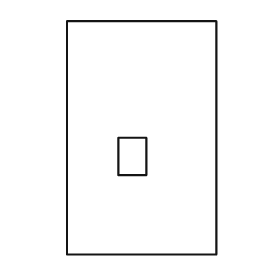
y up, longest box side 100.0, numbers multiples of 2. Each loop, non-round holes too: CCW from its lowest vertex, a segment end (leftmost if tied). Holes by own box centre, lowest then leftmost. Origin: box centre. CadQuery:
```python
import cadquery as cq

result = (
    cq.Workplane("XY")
    .moveTo(-32.0, -50.0)
    .lineTo(32.0, -50.0)
    .lineTo(32.0, 50.0)
    .lineTo(-32.0, 50.0)
    .close()
    .moveTo(-10.0, -16.0)
    .lineTo(2.0, -16.0)
    .lineTo(2.0, 0.0)
    .lineTo(-10.0, 0.0)
    .close()
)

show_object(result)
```